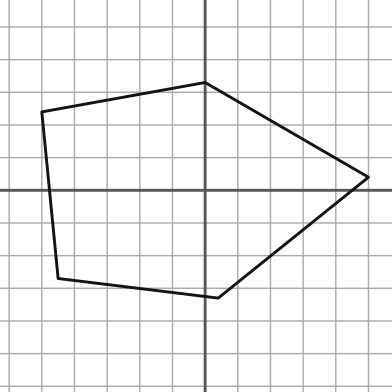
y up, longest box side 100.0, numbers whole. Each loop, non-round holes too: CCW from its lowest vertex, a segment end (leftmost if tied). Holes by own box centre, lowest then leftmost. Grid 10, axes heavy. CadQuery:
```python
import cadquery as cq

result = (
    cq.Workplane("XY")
    .moveTo(4.0, -33.0)
    .lineTo(50.0, 4.0)
    .lineTo(0.0, 33.0)
    .lineTo(-50.0, 24.0)
    .lineTo(-45.0, -27.0)
    .close()
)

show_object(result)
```